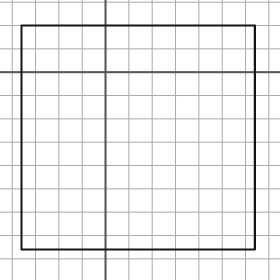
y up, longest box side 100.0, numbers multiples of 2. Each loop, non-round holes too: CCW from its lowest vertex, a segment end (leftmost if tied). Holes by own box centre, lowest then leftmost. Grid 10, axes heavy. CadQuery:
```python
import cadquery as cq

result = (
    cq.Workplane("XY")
    .moveTo(-36.0, -76.0)
    .lineTo(64.0, -76.0)
    .lineTo(64.0, 20.0)
    .lineTo(-36.0, 20.0)
    .close()
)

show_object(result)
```